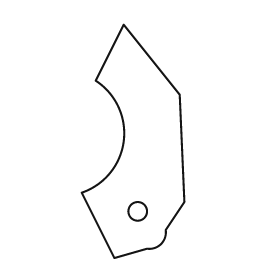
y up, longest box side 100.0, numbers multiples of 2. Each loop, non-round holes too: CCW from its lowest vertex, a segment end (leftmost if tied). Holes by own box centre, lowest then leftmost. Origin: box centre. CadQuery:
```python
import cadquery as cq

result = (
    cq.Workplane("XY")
    .moveTo(-8.0, -50.0)
    .lineTo(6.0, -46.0)
    .threePointArc((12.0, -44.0), (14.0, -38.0))
    .lineTo(22.0, -26.0)
    .lineTo(20.0, 20.0)
    .lineTo(-4.0, 50.0)
    .lineTo(-16.0, 26.0)
    .threePointArc((-4.0, 0.0), (-22.0, -22.0))
    .close()
    .moveTo(2.0, -30.0)
    .circle(4.0)
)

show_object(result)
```